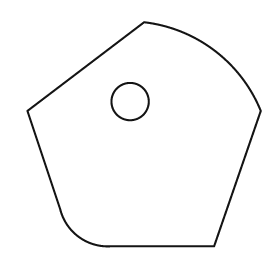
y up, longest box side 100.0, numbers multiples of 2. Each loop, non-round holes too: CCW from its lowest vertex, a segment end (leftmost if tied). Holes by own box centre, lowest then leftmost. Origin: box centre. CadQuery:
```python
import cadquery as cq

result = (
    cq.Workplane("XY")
    .moveTo(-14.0, -48.0)
    .lineTo(30.0, -48.0)
    .lineTo(50.0, 10.0)
    .threePointArc((30.0, 36.0), (0.0, 48.0))
    .lineTo(-50.0, 10.0)
    .lineTo(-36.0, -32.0)
    .threePointArc((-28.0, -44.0), (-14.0, -48.0))
    .close()
    .moveTo(-6.0, 14.0)
    .circle(8.0)
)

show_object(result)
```